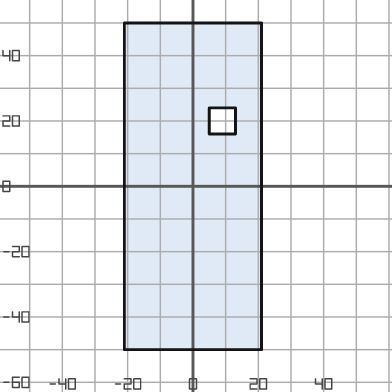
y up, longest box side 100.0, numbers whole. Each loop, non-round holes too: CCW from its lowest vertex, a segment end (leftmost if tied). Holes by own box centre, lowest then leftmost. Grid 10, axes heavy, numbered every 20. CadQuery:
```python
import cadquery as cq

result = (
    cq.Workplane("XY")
    .moveTo(-21.0, -50.0)
    .lineTo(21.0, -50.0)
    .lineTo(21.0, 50.0)
    .lineTo(-21.0, 50.0)
    .close()
    .moveTo(5.0, 16.0)
    .lineTo(13.0, 16.0)
    .lineTo(13.0, 24.0)
    .lineTo(5.0, 24.0)
    .close()
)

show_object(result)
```